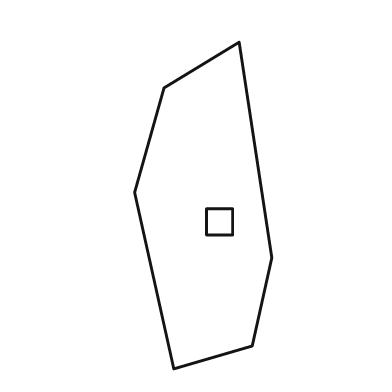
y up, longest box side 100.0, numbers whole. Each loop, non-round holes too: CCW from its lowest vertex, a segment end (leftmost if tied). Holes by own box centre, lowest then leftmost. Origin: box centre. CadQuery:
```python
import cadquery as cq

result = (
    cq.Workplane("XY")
    .moveTo(-9.0, -50.0)
    .lineTo(15.0, -43.0)
    .lineTo(21.0, -16.0)
    .lineTo(11.0, 50.0)
    .lineTo(-12.0, 36.0)
    .lineTo(-21.0, 4.0)
    .close()
    .moveTo(1.0, -9.0)
    .lineTo(9.0, -9.0)
    .lineTo(9.0, -1.0)
    .lineTo(1.0, -1.0)
    .close()
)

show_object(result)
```